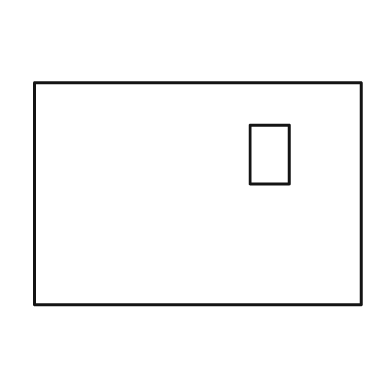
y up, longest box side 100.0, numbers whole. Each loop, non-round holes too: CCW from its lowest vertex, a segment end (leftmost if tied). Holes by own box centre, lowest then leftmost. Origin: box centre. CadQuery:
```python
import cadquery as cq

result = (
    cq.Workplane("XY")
    .moveTo(-50.0, -34.0)
    .lineTo(50.0, -34.0)
    .lineTo(50.0, 34.0)
    .lineTo(-50.0, 34.0)
    .close()
    .moveTo(16.0, 3.0)
    .lineTo(28.0, 3.0)
    .lineTo(28.0, 21.0)
    .lineTo(16.0, 21.0)
    .close()
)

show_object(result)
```